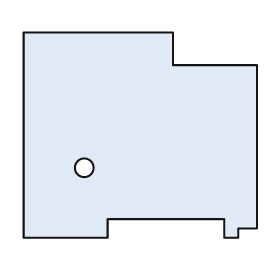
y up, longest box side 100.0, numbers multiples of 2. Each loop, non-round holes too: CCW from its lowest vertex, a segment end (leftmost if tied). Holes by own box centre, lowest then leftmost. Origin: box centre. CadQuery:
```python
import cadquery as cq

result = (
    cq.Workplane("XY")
    .moveTo(-50.0, -44.0)
    .lineTo(-14.0, -44.0)
    .lineTo(-14.0, -36.0)
    .lineTo(36.0, -36.0)
    .lineTo(36.0, -44.0)
    .lineTo(42.0, -44.0)
    .lineTo(42.0, -40.0)
    .lineTo(50.0, -40.0)
    .lineTo(50.0, 30.0)
    .lineTo(14.0, 30.0)
    .lineTo(14.0, 44.0)
    .lineTo(-50.0, 44.0)
    .close()
    .moveTo(-24.0, -14.0)
    .circle(4.0)
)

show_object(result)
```